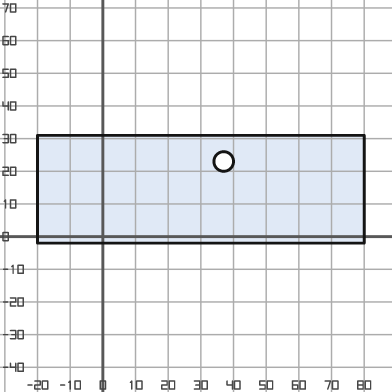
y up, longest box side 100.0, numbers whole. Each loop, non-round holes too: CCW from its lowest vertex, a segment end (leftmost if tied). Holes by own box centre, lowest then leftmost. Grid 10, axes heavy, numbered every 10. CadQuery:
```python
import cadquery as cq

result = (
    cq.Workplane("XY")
    .moveTo(-20.0, -2.0)
    .lineTo(80.0, -2.0)
    .lineTo(80.0, 31.0)
    .lineTo(-20.0, 31.0)
    .close()
    .moveTo(37.0, 23.0)
    .circle(3.0)
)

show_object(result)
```